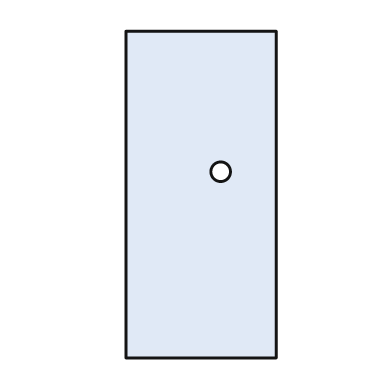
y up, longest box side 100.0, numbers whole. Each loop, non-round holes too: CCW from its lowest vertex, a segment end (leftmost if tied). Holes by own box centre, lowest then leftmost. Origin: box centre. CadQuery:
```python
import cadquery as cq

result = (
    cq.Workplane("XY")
    .moveTo(-23.0, -50.0)
    .lineTo(23.0, -50.0)
    .lineTo(23.0, 50.0)
    .lineTo(-23.0, 50.0)
    .close()
    .moveTo(6.0, 7.0)
    .circle(3.0)
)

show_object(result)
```